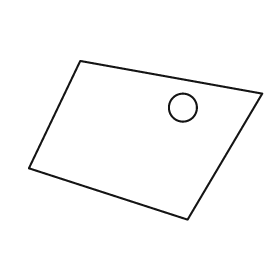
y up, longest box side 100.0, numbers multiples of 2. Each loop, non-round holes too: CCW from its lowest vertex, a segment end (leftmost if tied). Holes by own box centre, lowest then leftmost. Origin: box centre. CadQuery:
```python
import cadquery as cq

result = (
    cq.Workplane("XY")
    .moveTo(18.0, -34.0)
    .lineTo(50.0, 20.0)
    .lineTo(-28.0, 34.0)
    .lineTo(-50.0, -12.0)
    .close()
    .moveTo(16.0, 14.0)
    .circle(6.0)
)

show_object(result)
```